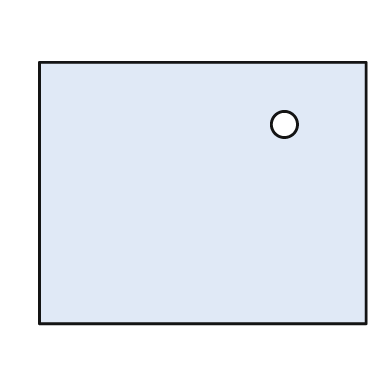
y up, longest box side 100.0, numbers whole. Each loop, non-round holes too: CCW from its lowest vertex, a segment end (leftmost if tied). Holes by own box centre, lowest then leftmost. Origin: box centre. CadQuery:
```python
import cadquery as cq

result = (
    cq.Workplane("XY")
    .moveTo(-50.0, -40.0)
    .lineTo(50.0, -40.0)
    .lineTo(50.0, 40.0)
    .lineTo(-50.0, 40.0)
    .close()
    .moveTo(25.0, 21.0)
    .circle(4.0)
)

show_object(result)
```